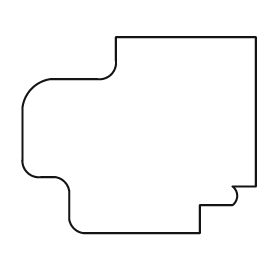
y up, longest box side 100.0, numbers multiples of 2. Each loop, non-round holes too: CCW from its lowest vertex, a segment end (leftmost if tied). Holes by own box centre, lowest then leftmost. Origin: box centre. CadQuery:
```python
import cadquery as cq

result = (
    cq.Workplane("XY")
    .moveTo(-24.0, -42.0)
    .lineTo(26.0, -42.0)
    .lineTo(26.0, -30.0)
    .lineTo(40.0, -30.0)
    .threePointArc((42.0, -26.0), (40.0, -22.0))
    .lineTo(50.0, -22.0)
    .lineTo(50.0, 42.0)
    .lineTo(-10.0, 42.0)
    .lineTo(-10.0, 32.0)
    .threePointArc((-12.0, 26.0), (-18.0, 24.0))
    .lineTo(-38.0, 24.0)
    .threePointArc((-46.0, 20.0), (-50.0, 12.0))
    .lineTo(-50.0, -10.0)
    .threePointArc((-48.0, -16.0), (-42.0, -18.0))
    .lineTo(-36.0, -18.0)
    .threePointArc((-32.0, -20.0), (-30.0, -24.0))
    .lineTo(-30.0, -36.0)
    .threePointArc((-28.0, -40.0), (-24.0, -42.0))
    .close()
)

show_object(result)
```